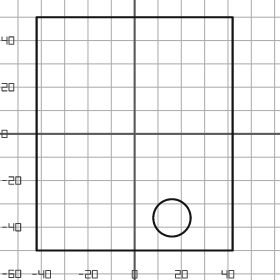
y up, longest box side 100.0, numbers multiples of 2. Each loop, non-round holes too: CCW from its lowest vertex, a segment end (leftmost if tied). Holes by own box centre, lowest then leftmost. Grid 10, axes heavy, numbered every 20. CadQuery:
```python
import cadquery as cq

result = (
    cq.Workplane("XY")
    .moveTo(-42.0, -50.0)
    .lineTo(42.0, -50.0)
    .lineTo(42.0, 50.0)
    .lineTo(-42.0, 50.0)
    .close()
    .moveTo(16.0, -36.0)
    .circle(8.0)
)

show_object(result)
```